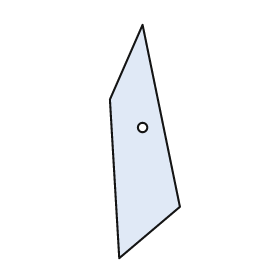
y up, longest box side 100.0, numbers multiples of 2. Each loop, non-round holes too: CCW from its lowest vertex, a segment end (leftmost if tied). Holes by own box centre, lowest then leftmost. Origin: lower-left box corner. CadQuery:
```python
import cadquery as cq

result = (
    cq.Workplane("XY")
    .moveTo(4.0, 0.0)
    .lineTo(30.0, 22.0)
    .lineTo(14.0, 100.0)
    .lineTo(0.0, 68.0)
    .close()
    .moveTo(14.0, 56.0)
    .circle(2.0)
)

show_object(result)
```